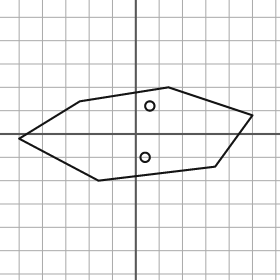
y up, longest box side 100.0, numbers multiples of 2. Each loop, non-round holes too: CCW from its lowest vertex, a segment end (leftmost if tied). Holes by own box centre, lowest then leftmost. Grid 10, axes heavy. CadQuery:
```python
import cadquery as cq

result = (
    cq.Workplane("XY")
    .moveTo(-16.0, -20.0)
    .lineTo(34.0, -14.0)
    .lineTo(50.0, 8.0)
    .lineTo(14.0, 20.0)
    .lineTo(-24.0, 14.0)
    .lineTo(-50.0, -2.0)
    .close()
    .moveTo(4.0, -10.0)
    .circle(2.0)
    .moveTo(6.0, 12.0)
    .circle(2.0)
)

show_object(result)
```